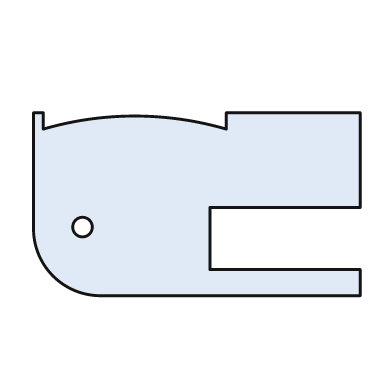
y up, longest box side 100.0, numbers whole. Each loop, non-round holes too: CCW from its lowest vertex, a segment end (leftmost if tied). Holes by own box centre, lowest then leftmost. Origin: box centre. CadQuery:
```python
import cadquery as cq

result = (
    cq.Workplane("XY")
    .moveTo(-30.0, -28.0)
    .lineTo(50.0, -28.0)
    .lineTo(50.0, -20.0)
    .lineTo(4.0, -20.0)
    .lineTo(4.0, -1.0)
    .lineTo(50.0, -1.0)
    .lineTo(50.0, 28.0)
    .lineTo(9.0, 28.0)
    .lineTo(9.0, 23.0)
    .threePointArc((-19.0, 27.0), (-47.0, 23.0))
    .lineTo(-47.0, 28.0)
    .lineTo(-50.0, 28.0)
    .lineTo(-50.0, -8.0)
    .threePointArc((-44.0, -22.0), (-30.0, -28.0))
    .close()
    .moveTo(-35.0, -7.0)
    .circle(3.0)
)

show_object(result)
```